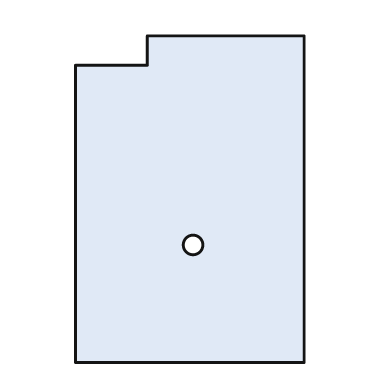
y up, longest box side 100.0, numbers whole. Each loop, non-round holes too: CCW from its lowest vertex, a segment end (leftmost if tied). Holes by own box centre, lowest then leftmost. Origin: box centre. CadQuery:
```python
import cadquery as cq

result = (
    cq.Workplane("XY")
    .moveTo(-35.0, -50.0)
    .lineTo(35.0, -50.0)
    .lineTo(35.0, 50.0)
    .lineTo(-13.0, 50.0)
    .lineTo(-13.0, 41.0)
    .lineTo(-35.0, 41.0)
    .close()
    .moveTo(1.0, -14.0)
    .circle(3.0)
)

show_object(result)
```